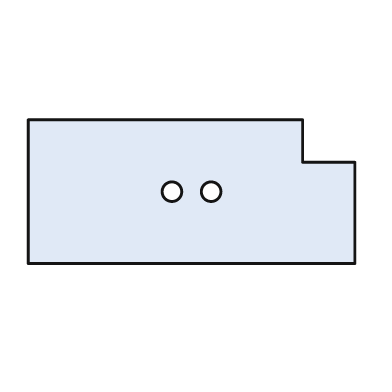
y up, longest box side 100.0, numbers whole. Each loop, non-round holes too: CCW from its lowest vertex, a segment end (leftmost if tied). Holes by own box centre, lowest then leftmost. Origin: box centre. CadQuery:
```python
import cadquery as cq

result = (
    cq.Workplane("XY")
    .moveTo(-50.0, -22.0)
    .lineTo(50.0, -22.0)
    .lineTo(50.0, 9.0)
    .lineTo(34.0, 9.0)
    .lineTo(34.0, 22.0)
    .lineTo(-50.0, 22.0)
    .close()
    .moveTo(-6.0, 0.0)
    .circle(3.0)
    .moveTo(6.0, 0.0)
    .circle(3.0)
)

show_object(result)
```